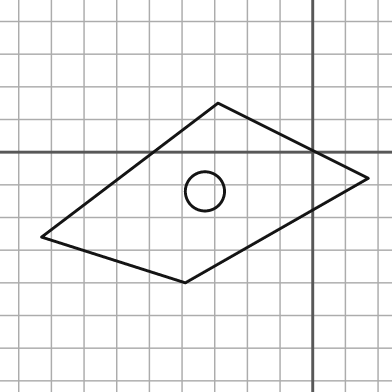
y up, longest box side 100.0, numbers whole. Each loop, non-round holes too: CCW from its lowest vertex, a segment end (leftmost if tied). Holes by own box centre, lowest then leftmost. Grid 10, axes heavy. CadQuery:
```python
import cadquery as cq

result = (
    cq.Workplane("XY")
    .moveTo(-39.0, -40.0)
    .lineTo(17.0, -8.0)
    .lineTo(-29.0, 15.0)
    .lineTo(-83.0, -26.0)
    .close()
    .moveTo(-33.0, -12.0)
    .circle(6.0)
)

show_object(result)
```